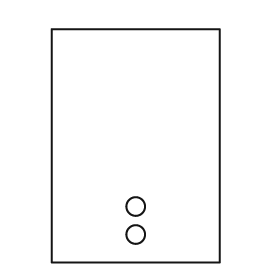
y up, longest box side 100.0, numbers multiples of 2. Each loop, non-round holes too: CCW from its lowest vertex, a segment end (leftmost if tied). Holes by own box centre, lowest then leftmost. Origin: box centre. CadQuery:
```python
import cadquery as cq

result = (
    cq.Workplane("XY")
    .moveTo(-36.0, -50.0)
    .lineTo(36.0, -50.0)
    .lineTo(36.0, 50.0)
    .lineTo(-36.0, 50.0)
    .close()
    .moveTo(0.0, -38.0)
    .circle(4.0)
    .moveTo(0.0, -26.0)
    .circle(4.0)
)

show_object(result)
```